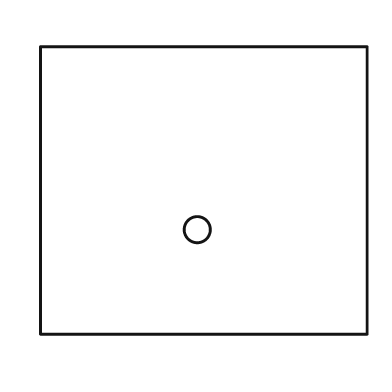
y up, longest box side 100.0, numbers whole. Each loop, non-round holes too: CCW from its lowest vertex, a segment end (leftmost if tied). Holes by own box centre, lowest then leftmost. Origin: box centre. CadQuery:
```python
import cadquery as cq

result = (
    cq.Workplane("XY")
    .moveTo(-50.0, -44.0)
    .lineTo(50.0, -44.0)
    .lineTo(50.0, 44.0)
    .lineTo(-50.0, 44.0)
    .close()
    .moveTo(-2.0, -12.0)
    .circle(4.0)
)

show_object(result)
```